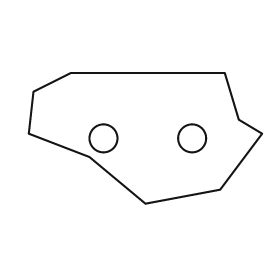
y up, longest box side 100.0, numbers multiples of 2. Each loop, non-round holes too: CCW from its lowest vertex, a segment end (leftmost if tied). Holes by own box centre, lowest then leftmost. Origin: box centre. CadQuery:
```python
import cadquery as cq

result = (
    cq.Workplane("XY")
    .moveTo(0.0, -28.0)
    .lineTo(32.0, -22.0)
    .lineTo(50.0, 2.0)
    .lineTo(40.0, 8.0)
    .lineTo(34.0, 28.0)
    .lineTo(-32.0, 28.0)
    .lineTo(-48.0, 20.0)
    .lineTo(-50.0, 2.0)
    .lineTo(-24.0, -8.0)
    .close()
    .moveTo(-18.0, 0.0)
    .circle(6.0)
    .moveTo(20.0, 0.0)
    .circle(6.0)
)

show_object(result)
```